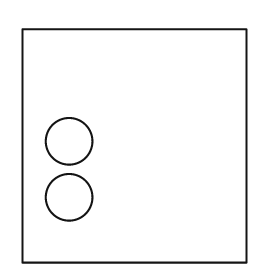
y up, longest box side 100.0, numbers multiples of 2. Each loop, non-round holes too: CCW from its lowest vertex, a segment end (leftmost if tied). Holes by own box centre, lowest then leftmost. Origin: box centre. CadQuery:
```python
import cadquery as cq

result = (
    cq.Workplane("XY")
    .moveTo(-48.0, -50.0)
    .lineTo(48.0, -50.0)
    .lineTo(48.0, 50.0)
    .lineTo(-48.0, 50.0)
    .close()
    .moveTo(-28.0, -22.0)
    .circle(10.0)
    .moveTo(-28.0, 2.0)
    .circle(10.0)
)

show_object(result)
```